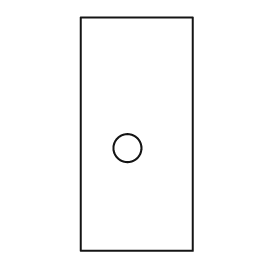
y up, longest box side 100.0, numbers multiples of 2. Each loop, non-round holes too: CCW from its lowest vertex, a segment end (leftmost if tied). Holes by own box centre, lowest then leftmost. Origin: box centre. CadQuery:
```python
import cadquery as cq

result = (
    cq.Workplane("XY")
    .moveTo(-24.0, -50.0)
    .lineTo(24.0, -50.0)
    .lineTo(24.0, 50.0)
    .lineTo(-24.0, 50.0)
    .close()
    .moveTo(-4.0, -6.0)
    .circle(6.0)
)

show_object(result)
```